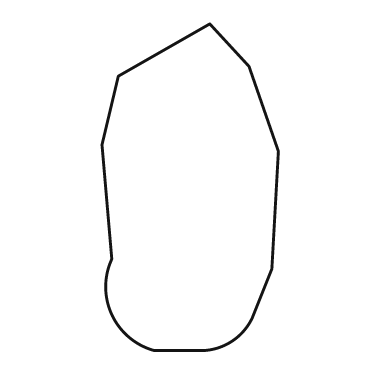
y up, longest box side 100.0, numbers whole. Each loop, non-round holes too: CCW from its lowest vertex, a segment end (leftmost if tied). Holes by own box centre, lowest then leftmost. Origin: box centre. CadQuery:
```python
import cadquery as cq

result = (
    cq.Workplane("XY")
    .moveTo(-11.0, -50.0)
    .lineTo(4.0, -50.0)
    .threePointArc((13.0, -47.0), (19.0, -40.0))
    .lineTo(25.0, -25.0)
    .lineTo(27.0, 11.0)
    .lineTo(18.0, 37.0)
    .lineTo(6.0, 50.0)
    .lineTo(-22.0, 34.0)
    .lineTo(-27.0, 13.0)
    .lineTo(-24.0, -22.0)
    .threePointArc((-24.0, -39.0), (-11.0, -50.0))
    .close()
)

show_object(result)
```